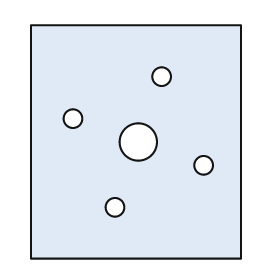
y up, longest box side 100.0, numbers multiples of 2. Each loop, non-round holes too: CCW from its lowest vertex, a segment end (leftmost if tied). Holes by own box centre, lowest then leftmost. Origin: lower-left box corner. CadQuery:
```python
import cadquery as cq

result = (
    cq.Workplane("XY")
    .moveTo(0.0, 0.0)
    .lineTo(90.0, 0.0)
    .lineTo(90.0, 100.0)
    .lineTo(0.0, 100.0)
    .close()
    .moveTo(36.0, 22.0)
    .circle(4.0)
    .moveTo(74.0, 40.0)
    .circle(4.0)
    .moveTo(46.0, 50.0)
    .circle(8.0)
    .moveTo(18.0, 60.0)
    .circle(4.0)
    .moveTo(56.0, 78.0)
    .circle(4.0)
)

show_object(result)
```